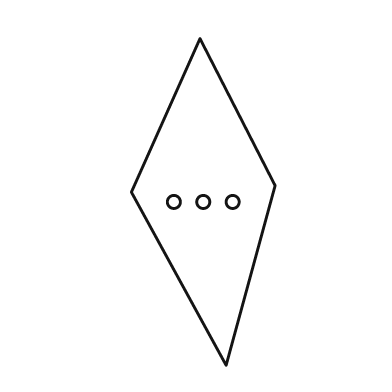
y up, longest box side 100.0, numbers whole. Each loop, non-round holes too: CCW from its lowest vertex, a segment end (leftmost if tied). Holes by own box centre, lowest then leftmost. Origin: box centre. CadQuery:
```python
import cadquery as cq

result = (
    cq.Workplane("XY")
    .moveTo(7.0, -50.0)
    .lineTo(22.0, 5.0)
    .lineTo(-1.0, 50.0)
    .lineTo(-22.0, 3.0)
    .close()
    .moveTo(-9.0, 0.0)
    .circle(2.0)
    .moveTo(0.0, 0.0)
    .circle(2.0)
    .moveTo(9.0, 0.0)
    .circle(2.0)
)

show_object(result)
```